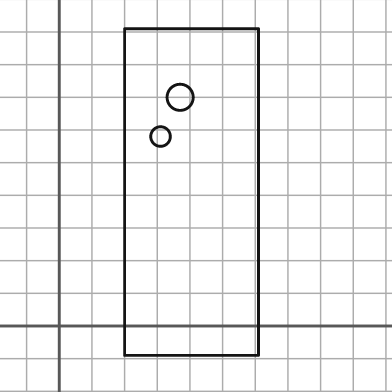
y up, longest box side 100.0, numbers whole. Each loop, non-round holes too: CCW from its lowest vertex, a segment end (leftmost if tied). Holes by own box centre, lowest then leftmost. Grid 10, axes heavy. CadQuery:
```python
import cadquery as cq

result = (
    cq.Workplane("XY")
    .moveTo(20.0, -9.0)
    .lineTo(61.0, -9.0)
    .lineTo(61.0, 91.0)
    .lineTo(20.0, 91.0)
    .close()
    .moveTo(31.0, 58.0)
    .circle(3.0)
    .moveTo(37.0, 70.0)
    .circle(4.0)
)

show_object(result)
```